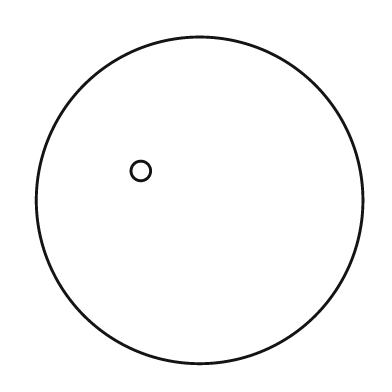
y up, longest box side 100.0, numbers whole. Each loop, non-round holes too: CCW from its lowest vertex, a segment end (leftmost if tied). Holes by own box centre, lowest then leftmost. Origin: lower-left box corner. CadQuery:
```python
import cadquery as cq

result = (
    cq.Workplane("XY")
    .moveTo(50.0, 50.0)
    .circle(50.0)
    .moveTo(32.0, 59.0)
    .circle(3.0)
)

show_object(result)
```